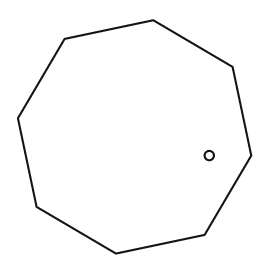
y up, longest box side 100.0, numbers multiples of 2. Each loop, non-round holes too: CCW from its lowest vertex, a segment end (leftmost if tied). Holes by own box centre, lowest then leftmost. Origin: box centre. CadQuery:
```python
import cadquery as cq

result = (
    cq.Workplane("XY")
    .moveTo(-8.0, -50.0)
    .lineTo(30.0, -42.0)
    .lineTo(50.0, -8.0)
    .lineTo(42.0, 30.0)
    .lineTo(8.0, 50.0)
    .lineTo(-30.0, 42.0)
    .lineTo(-50.0, 8.0)
    .lineTo(-42.0, -30.0)
    .close()
    .moveTo(32.0, -8.0)
    .circle(2.0)
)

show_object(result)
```